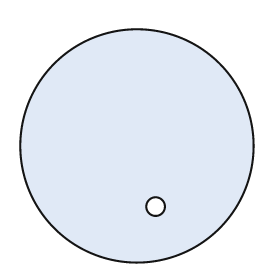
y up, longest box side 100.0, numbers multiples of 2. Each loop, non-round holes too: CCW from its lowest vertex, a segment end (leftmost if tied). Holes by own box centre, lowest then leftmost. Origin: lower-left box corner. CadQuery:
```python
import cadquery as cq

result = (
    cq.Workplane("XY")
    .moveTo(50.0, 50.0)
    .circle(50.0)
    .moveTo(58.0, 24.0)
    .circle(4.0)
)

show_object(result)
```